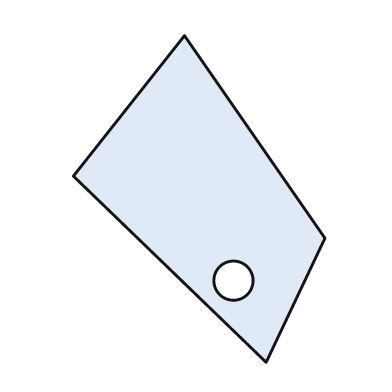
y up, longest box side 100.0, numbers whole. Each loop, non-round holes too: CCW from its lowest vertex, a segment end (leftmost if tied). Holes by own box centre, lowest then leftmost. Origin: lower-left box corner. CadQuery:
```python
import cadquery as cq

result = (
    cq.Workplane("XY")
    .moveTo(59.0, 0.0)
    .lineTo(77.0, 38.0)
    .lineTo(34.0, 100.0)
    .lineTo(0.0, 57.0)
    .close()
    .moveTo(49.0, 25.0)
    .circle(6.0)
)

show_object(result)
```